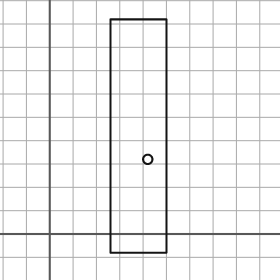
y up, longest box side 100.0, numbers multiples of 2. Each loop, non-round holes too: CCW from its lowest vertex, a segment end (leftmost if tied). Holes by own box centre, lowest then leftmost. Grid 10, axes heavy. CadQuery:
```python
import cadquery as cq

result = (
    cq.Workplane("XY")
    .moveTo(26.0, -8.0)
    .lineTo(50.0, -8.0)
    .lineTo(50.0, 92.0)
    .lineTo(26.0, 92.0)
    .close()
    .moveTo(42.0, 32.0)
    .circle(2.0)
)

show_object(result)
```